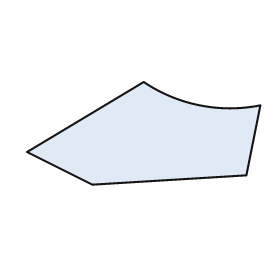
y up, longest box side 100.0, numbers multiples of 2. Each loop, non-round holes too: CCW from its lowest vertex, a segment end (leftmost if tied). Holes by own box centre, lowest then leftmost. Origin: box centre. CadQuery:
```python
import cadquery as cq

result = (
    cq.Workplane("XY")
    .moveTo(-22.0, -22.0)
    .lineTo(44.0, -18.0)
    .lineTo(50.0, 12.0)
    .threePointArc((24.0, 12.0), (0.0, 22.0))
    .lineTo(-50.0, -8.0)
    .close()
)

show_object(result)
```